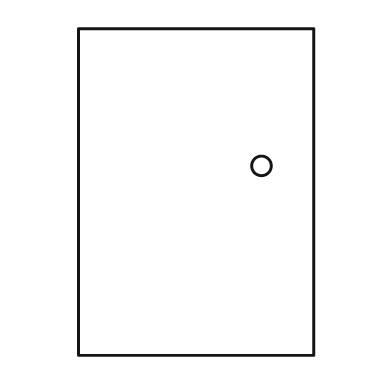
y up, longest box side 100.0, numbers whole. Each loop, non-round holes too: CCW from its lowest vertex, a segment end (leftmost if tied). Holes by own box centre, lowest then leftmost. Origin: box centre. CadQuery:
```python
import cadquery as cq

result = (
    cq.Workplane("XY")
    .moveTo(-36.0, -50.0)
    .lineTo(36.0, -50.0)
    .lineTo(36.0, 50.0)
    .lineTo(-36.0, 50.0)
    .close()
    .moveTo(20.0, 8.0)
    .circle(3.0)
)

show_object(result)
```